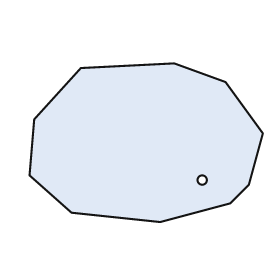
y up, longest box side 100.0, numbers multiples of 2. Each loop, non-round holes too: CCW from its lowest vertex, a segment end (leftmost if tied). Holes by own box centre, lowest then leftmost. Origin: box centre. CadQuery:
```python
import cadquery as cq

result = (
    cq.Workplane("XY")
    .moveTo(6.0, -34.0)
    .lineTo(36.0, -26.0)
    .lineTo(44.0, -18.0)
    .lineTo(50.0, 4.0)
    .lineTo(34.0, 26.0)
    .lineTo(12.0, 34.0)
    .lineTo(-28.0, 32.0)
    .lineTo(-48.0, 10.0)
    .lineTo(-50.0, -14.0)
    .lineTo(-32.0, -30.0)
    .close()
    .moveTo(24.0, -16.0)
    .circle(2.0)
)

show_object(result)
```